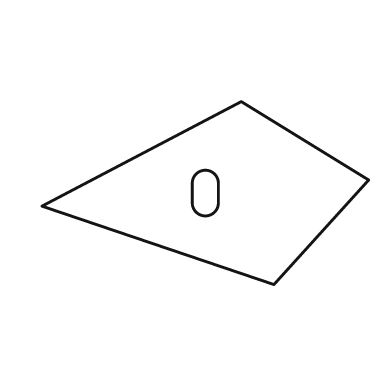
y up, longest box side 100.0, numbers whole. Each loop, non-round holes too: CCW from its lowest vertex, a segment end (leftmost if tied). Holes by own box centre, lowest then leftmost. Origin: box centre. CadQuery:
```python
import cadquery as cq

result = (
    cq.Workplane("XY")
    .moveTo(21.0, -28.0)
    .lineTo(50.0, 4.0)
    .lineTo(11.0, 28.0)
    .lineTo(-50.0, -4.0)
    .close()
    .moveTo(-4.0, -3.0)
    .threePointArc((0.0, -7.0), (4.0, -3.0))
    .lineTo(4.0, 3.0)
    .threePointArc((0.0, 7.0), (-4.0, 3.0))
    .close()
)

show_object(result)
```